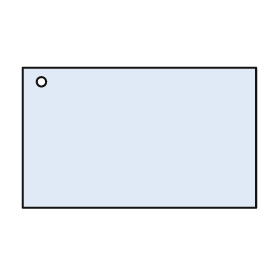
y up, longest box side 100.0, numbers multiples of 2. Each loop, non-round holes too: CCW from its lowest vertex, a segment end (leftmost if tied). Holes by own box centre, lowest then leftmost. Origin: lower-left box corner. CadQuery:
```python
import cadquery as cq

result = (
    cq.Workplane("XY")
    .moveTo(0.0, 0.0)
    .lineTo(100.0, 0.0)
    .lineTo(100.0, 60.0)
    .lineTo(0.0, 60.0)
    .close()
    .moveTo(8.0, 54.0)
    .circle(2.0)
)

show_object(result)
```